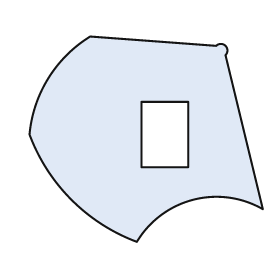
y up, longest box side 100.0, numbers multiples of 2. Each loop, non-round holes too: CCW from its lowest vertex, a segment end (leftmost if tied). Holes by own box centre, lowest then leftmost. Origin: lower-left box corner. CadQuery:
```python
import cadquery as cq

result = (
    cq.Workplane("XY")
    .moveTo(46.0, 0.0)
    .threePointArc((70.0, 18.0), (100.0, 14.0))
    .lineTo(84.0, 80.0)
    .threePointArc((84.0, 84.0), (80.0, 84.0))
    .lineTo(26.0, 88.0)
    .threePointArc((8.0, 70.0), (0.0, 46.0))
    .threePointArc((18.0, 18.0), (46.0, 0.0))
    .close()
    .moveTo(48.0, 32.0)
    .lineTo(68.0, 32.0)
    .lineTo(68.0, 60.0)
    .lineTo(48.0, 60.0)
    .close()
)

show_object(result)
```